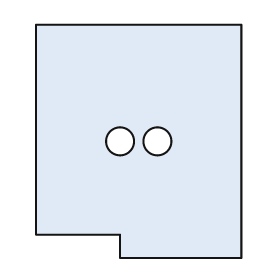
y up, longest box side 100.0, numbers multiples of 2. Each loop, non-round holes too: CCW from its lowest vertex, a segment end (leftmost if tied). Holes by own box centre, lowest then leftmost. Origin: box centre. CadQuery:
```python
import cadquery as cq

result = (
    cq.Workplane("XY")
    .moveTo(-8.0, -50.0)
    .lineTo(44.0, -50.0)
    .lineTo(44.0, 50.0)
    .lineTo(-44.0, 50.0)
    .lineTo(-44.0, -40.0)
    .lineTo(-8.0, -40.0)
    .close()
    .moveTo(-8.0, 0.0)
    .circle(6.0)
    .moveTo(8.0, 0.0)
    .circle(6.0)
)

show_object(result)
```